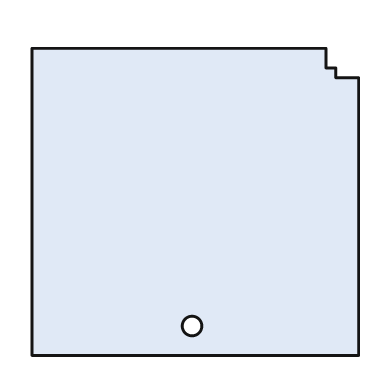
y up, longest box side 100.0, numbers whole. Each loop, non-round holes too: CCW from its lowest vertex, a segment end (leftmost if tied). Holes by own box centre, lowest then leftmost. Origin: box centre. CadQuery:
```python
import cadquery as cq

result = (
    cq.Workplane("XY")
    .moveTo(-50.0, -47.0)
    .lineTo(50.0, -47.0)
    .lineTo(50.0, 38.0)
    .lineTo(43.0, 38.0)
    .lineTo(43.0, 41.0)
    .lineTo(40.0, 41.0)
    .lineTo(40.0, 47.0)
    .lineTo(-50.0, 47.0)
    .close()
    .moveTo(-1.0, -38.0)
    .circle(3.0)
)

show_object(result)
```